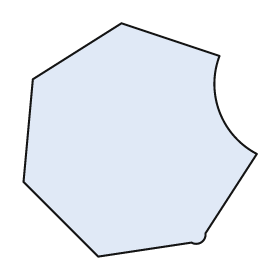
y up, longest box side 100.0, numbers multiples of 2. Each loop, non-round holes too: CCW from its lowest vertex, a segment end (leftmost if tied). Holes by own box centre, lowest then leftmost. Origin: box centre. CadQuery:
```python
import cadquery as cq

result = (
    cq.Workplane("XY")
    .moveTo(-18.0, -50.0)
    .lineTo(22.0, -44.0)
    .threePointArc((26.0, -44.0), (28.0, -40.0))
    .lineTo(50.0, -6.0)
    .threePointArc((34.0, 12.0), (34.0, 36.0))
    .lineTo(-8.0, 50.0)
    .lineTo(-46.0, 26.0)
    .lineTo(-50.0, -18.0)
    .close()
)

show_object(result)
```